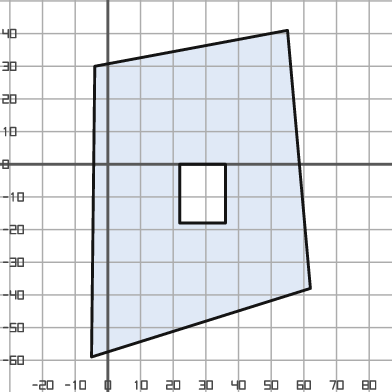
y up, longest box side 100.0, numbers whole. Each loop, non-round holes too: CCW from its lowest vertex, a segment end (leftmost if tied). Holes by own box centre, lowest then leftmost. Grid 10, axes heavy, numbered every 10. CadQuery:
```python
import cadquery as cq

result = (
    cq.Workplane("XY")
    .moveTo(-5.0, -59.0)
    .lineTo(62.0, -38.0)
    .lineTo(55.0, 41.0)
    .lineTo(-4.0, 30.0)
    .close()
    .moveTo(22.0, -18.0)
    .lineTo(36.0, -18.0)
    .lineTo(36.0, 0.0)
    .lineTo(22.0, 0.0)
    .close()
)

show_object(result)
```